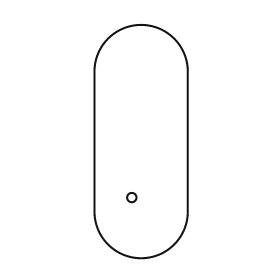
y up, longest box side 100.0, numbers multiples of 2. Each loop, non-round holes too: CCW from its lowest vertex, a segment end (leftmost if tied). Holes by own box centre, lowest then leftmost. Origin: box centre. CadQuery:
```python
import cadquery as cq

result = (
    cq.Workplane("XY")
    .moveTo(-20.0, -30.0)
    .threePointArc((0.0, -50.0), (20.0, -30.0))
    .lineTo(20.0, 30.0)
    .threePointArc((0.0, 50.0), (-20.0, 30.0))
    .close()
    .moveTo(-4.0, -24.0)
    .circle(2.0)
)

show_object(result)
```